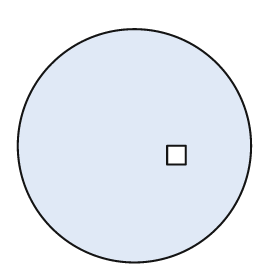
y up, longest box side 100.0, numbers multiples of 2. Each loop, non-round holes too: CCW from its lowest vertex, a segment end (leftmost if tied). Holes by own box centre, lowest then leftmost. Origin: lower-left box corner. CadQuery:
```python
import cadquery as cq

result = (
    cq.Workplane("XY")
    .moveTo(50.0, 50.0)
    .circle(50.0)
    .moveTo(64.0, 42.0)
    .lineTo(72.0, 42.0)
    .lineTo(72.0, 50.0)
    .lineTo(64.0, 50.0)
    .close()
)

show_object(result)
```